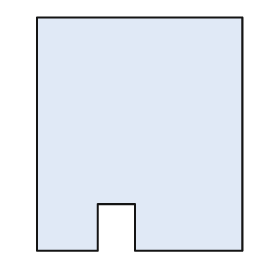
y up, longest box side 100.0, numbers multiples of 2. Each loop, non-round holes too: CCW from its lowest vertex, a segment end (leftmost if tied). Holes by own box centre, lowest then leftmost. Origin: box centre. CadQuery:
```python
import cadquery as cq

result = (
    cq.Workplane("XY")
    .moveTo(-44.0, -50.0)
    .lineTo(-18.0, -50.0)
    .lineTo(-18.0, -30.0)
    .lineTo(-2.0, -30.0)
    .lineTo(-2.0, -50.0)
    .lineTo(44.0, -50.0)
    .lineTo(44.0, 50.0)
    .lineTo(-44.0, 50.0)
    .close()
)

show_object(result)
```